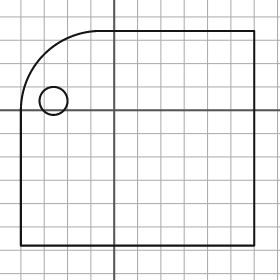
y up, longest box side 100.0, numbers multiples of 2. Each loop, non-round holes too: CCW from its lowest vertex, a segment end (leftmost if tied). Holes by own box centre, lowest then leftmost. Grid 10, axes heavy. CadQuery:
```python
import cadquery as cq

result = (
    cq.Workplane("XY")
    .moveTo(-40.0, -58.0)
    .lineTo(60.0, -58.0)
    .lineTo(60.0, 34.0)
    .lineTo(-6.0, 34.0)
    .threePointArc((-30.0, 24.0), (-40.0, 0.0))
    .close()
    .moveTo(-26.0, 4.0)
    .circle(6.0)
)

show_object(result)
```